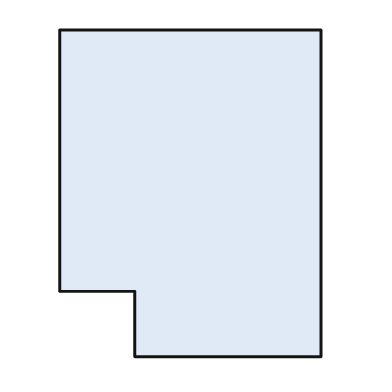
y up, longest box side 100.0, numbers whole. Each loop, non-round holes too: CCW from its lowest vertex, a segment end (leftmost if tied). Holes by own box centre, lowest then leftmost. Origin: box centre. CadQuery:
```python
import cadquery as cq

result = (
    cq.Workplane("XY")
    .moveTo(-17.0, -50.0)
    .lineTo(40.0, -50.0)
    .lineTo(40.0, 50.0)
    .lineTo(-40.0, 50.0)
    .lineTo(-40.0, -30.0)
    .lineTo(-17.0, -30.0)
    .close()
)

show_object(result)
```